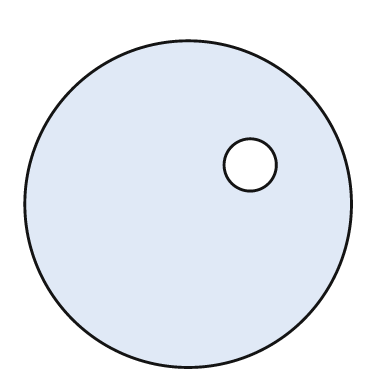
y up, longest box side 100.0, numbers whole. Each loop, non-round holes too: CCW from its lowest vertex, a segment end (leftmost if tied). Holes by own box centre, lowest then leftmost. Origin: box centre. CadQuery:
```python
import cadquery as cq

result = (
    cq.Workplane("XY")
    .moveTo(0.0, 0.0)
    .circle(50.0)
    .moveTo(19.0, 12.0)
    .circle(8.0)
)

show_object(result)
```